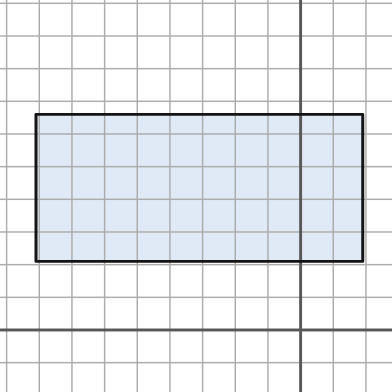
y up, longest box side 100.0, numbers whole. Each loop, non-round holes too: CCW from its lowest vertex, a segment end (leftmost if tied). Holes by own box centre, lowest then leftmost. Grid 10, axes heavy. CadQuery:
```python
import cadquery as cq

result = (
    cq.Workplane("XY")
    .moveTo(-81.0, 21.0)
    .lineTo(19.0, 21.0)
    .lineTo(19.0, 66.0)
    .lineTo(-81.0, 66.0)
    .close()
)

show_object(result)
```